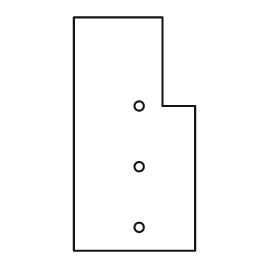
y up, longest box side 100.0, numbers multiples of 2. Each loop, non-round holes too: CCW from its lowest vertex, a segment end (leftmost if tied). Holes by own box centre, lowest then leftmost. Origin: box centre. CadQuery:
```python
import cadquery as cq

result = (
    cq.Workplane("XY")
    .moveTo(-26.0, -50.0)
    .lineTo(26.0, -50.0)
    .lineTo(26.0, 12.0)
    .lineTo(12.0, 12.0)
    .lineTo(12.0, 50.0)
    .lineTo(-26.0, 50.0)
    .close()
    .moveTo(2.0, -40.0)
    .circle(2.0)
    .moveTo(2.0, -14.0)
    .circle(2.0)
    .moveTo(2.0, 12.0)
    .circle(2.0)
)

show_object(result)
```